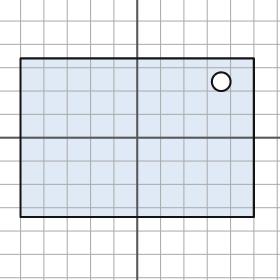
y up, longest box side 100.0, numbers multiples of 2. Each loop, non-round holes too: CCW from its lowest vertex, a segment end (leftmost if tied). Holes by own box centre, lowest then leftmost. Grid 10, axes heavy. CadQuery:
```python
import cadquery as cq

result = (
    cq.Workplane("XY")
    .moveTo(-50.0, -34.0)
    .lineTo(50.0, -34.0)
    .lineTo(50.0, 34.0)
    .lineTo(-50.0, 34.0)
    .close()
    .moveTo(36.0, 24.0)
    .circle(4.0)
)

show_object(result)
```